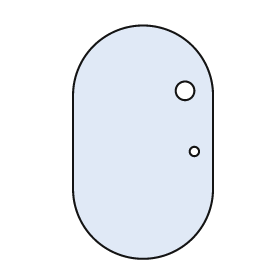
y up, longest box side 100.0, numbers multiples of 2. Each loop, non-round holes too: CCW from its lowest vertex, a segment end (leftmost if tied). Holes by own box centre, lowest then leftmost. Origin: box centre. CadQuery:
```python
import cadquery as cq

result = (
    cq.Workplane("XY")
    .moveTo(-30.0, -20.0)
    .threePointArc((0.0, -50.0), (30.0, -20.0))
    .lineTo(30.0, 20.0)
    .threePointArc((0.0, 50.0), (-30.0, 20.0))
    .close()
    .moveTo(22.0, -4.0)
    .circle(2.0)
    .moveTo(18.0, 22.0)
    .circle(4.0)
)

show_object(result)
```